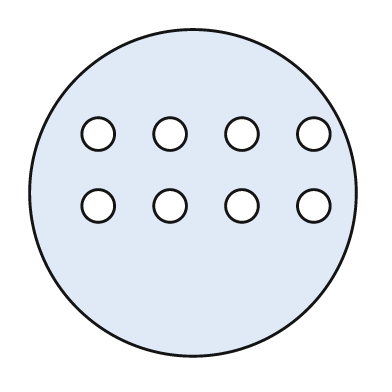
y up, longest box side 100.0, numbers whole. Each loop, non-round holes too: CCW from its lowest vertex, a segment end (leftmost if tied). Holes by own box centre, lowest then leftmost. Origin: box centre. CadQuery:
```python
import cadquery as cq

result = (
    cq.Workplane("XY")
    .moveTo(0.0, 0.0)
    .circle(50.0)
    .moveTo(-29.0, -4.0)
    .circle(5.0)
    .moveTo(-7.0, -4.0)
    .circle(5.0)
    .moveTo(15.0, -4.0)
    .circle(5.0)
    .moveTo(37.0, -4.0)
    .circle(5.0)
    .moveTo(-29.0, 18.0)
    .circle(5.0)
    .moveTo(-7.0, 18.0)
    .circle(5.0)
    .moveTo(15.0, 18.0)
    .circle(5.0)
    .moveTo(37.0, 18.0)
    .circle(5.0)
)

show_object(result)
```